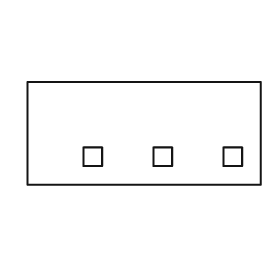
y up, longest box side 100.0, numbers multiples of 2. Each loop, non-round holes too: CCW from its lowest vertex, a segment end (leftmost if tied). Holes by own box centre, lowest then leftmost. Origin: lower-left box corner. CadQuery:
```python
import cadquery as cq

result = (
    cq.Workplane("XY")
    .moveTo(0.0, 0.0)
    .lineTo(100.0, 0.0)
    .lineTo(100.0, 44.0)
    .lineTo(0.0, 44.0)
    .close()
    .moveTo(24.0, 8.0)
    .lineTo(32.0, 8.0)
    .lineTo(32.0, 16.0)
    .lineTo(24.0, 16.0)
    .close()
    .moveTo(54.0, 8.0)
    .lineTo(62.0, 8.0)
    .lineTo(62.0, 16.0)
    .lineTo(54.0, 16.0)
    .close()
    .moveTo(84.0, 8.0)
    .lineTo(92.0, 8.0)
    .lineTo(92.0, 16.0)
    .lineTo(84.0, 16.0)
    .close()
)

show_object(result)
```